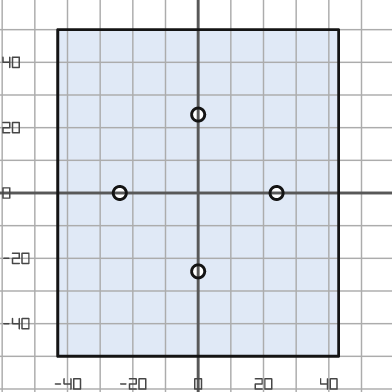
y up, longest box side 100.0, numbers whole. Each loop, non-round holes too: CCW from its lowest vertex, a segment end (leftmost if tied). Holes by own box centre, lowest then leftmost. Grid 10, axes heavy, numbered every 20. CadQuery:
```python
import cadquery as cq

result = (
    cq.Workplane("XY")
    .moveTo(-43.0, -50.0)
    .lineTo(43.0, -50.0)
    .lineTo(43.0, 50.0)
    .lineTo(-43.0, 50.0)
    .close()
    .moveTo(0.0, -24.0)
    .circle(2.0)
    .moveTo(-24.0, 0.0)
    .circle(2.0)
    .moveTo(24.0, 0.0)
    .circle(2.0)
    .moveTo(0.0, 24.0)
    .circle(2.0)
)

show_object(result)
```